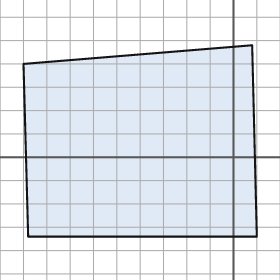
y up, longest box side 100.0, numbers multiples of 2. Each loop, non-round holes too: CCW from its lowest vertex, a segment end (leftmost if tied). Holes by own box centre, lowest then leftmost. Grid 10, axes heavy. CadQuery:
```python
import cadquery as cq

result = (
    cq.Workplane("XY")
    .moveTo(-88.0, -34.0)
    .lineTo(10.0, -34.0)
    .lineTo(8.0, 48.0)
    .lineTo(-90.0, 40.0)
    .close()
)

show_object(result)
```